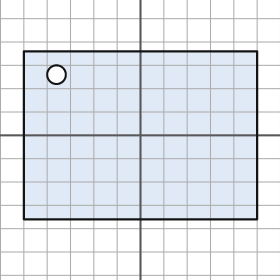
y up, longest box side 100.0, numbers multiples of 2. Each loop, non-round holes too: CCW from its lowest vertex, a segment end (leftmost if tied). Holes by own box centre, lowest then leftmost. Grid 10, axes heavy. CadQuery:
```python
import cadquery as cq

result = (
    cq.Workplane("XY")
    .moveTo(-50.0, -36.0)
    .lineTo(50.0, -36.0)
    .lineTo(50.0, 36.0)
    .lineTo(-50.0, 36.0)
    .close()
    .moveTo(-36.0, 26.0)
    .circle(4.0)
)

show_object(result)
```